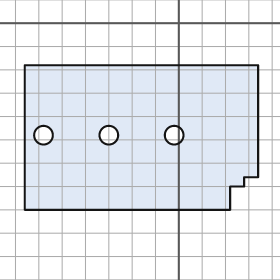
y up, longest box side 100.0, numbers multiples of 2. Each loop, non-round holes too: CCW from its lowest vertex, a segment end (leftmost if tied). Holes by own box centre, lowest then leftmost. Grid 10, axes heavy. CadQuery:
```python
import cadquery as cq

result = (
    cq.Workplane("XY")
    .moveTo(-66.0, -80.0)
    .lineTo(22.0, -80.0)
    .lineTo(22.0, -70.0)
    .lineTo(28.0, -70.0)
    .lineTo(28.0, -66.0)
    .lineTo(34.0, -66.0)
    .lineTo(34.0, -18.0)
    .lineTo(-66.0, -18.0)
    .close()
    .moveTo(-58.0, -48.0)
    .circle(4.0)
    .moveTo(-30.0, -48.0)
    .circle(4.0)
    .moveTo(-2.0, -48.0)
    .circle(4.0)
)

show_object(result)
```